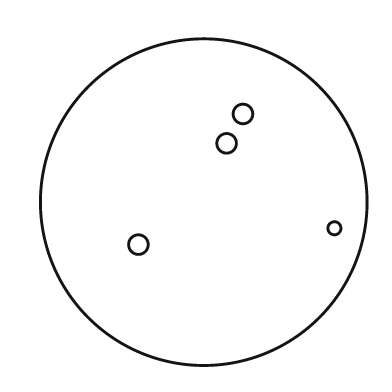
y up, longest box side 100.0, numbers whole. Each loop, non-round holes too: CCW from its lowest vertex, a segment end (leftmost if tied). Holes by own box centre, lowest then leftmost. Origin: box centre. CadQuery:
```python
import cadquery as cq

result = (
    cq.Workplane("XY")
    .moveTo(0.0, 0.0)
    .circle(50.0)
    .moveTo(-20.0, -13.0)
    .circle(3.0)
    .moveTo(40.0, -8.0)
    .circle(2.0)
    .moveTo(7.0, 18.0)
    .circle(3.0)
    .moveTo(12.0, 27.0)
    .circle(3.0)
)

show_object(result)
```